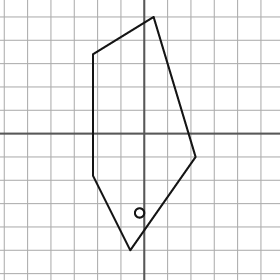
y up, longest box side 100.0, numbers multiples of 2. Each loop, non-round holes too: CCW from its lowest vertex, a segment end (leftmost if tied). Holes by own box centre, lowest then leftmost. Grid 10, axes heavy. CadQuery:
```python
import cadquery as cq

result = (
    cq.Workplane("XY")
    .moveTo(-6.0, -50.0)
    .lineTo(22.0, -10.0)
    .lineTo(4.0, 50.0)
    .lineTo(-22.0, 34.0)
    .lineTo(-22.0, -18.0)
    .close()
    .moveTo(-2.0, -34.0)
    .circle(2.0)
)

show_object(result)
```